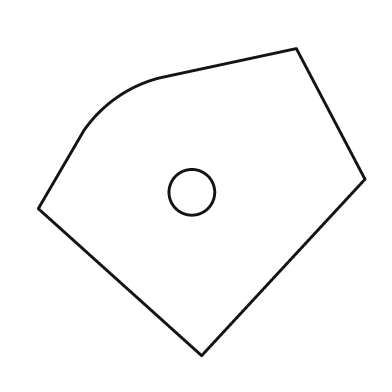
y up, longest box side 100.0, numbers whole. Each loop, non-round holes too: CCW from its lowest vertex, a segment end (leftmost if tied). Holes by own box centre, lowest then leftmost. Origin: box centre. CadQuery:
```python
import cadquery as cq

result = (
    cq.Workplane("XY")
    .moveTo(0.0, -47.0)
    .lineTo(50.0, 7.0)
    .lineTo(29.0, 47.0)
    .lineTo(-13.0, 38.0)
    .threePointArc((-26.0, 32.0), (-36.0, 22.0))
    .lineTo(-50.0, -2.0)
    .close()
    .moveTo(-3.0, 3.0)
    .circle(7.0)
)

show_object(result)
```